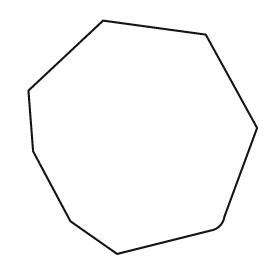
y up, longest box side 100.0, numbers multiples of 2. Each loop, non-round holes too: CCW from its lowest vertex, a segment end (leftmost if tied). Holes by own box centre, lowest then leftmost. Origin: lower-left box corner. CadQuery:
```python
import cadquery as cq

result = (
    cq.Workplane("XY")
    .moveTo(38.0, 0.0)
    .lineTo(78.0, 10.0)
    .threePointArc((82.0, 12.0), (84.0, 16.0))
    .lineTo(98.0, 54.0)
    .lineTo(76.0, 94.0)
    .lineTo(32.0, 100.0)
    .lineTo(0.0, 70.0)
    .lineTo(2.0, 44.0)
    .lineTo(18.0, 14.0)
    .close()
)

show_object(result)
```